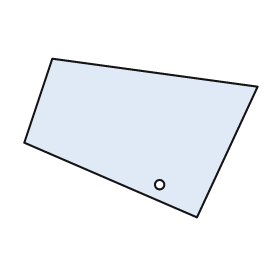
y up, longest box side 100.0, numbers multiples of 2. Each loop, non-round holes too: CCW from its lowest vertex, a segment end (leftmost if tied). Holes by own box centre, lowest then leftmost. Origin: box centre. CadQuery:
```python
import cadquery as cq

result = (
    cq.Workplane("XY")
    .moveTo(24.0, -34.0)
    .lineTo(50.0, 22.0)
    .lineTo(-38.0, 34.0)
    .lineTo(-50.0, -2.0)
    .close()
    .moveTo(8.0, -20.0)
    .circle(2.0)
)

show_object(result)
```